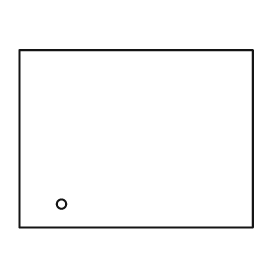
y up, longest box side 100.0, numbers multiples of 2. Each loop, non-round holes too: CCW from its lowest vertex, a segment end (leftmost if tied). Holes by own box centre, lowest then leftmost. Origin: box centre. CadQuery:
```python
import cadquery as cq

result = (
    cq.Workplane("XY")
    .moveTo(-50.0, -38.0)
    .lineTo(50.0, -38.0)
    .lineTo(50.0, 38.0)
    .lineTo(-50.0, 38.0)
    .close()
    .moveTo(-32.0, -28.0)
    .circle(2.0)
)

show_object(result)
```